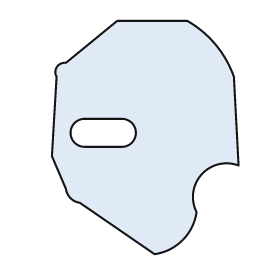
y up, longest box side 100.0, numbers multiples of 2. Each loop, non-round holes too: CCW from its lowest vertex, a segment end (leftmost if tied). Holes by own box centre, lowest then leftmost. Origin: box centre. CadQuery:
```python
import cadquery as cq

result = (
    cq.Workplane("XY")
    .moveTo(4.0, -50.0)
    .threePointArc((16.0, -44.0), (22.0, -32.0))
    .threePointArc((24.0, -16.0), (40.0, -12.0))
    .lineTo(38.0, 26.0)
    .threePointArc((30.0, 40.0), (18.0, 50.0))
    .lineTo(-12.0, 50.0)
    .lineTo(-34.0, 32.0)
    .threePointArc((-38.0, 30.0), (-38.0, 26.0))
    .lineTo(-40.0, -8.0)
    .lineTo(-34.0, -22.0)
    .threePointArc((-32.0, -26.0), (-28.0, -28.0))
    .close()
    .moveTo(-26.0, -4.0)
    .lineTo(-10.0, -4.0)
    .threePointArc((-4.0, 2.0), (-10.0, 8.0))
    .lineTo(-26.0, 8.0)
    .threePointArc((-32.0, 2.0), (-26.0, -4.0))
    .close()
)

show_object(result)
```